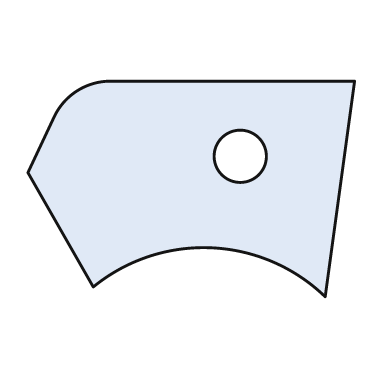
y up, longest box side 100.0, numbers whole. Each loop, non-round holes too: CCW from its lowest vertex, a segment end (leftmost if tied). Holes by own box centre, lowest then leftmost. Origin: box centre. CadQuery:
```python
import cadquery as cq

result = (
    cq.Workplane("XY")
    .moveTo(41.0, -33.0)
    .lineTo(50.0, 33.0)
    .lineTo(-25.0, 33.0)
    .threePointArc((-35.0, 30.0), (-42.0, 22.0))
    .lineTo(-50.0, 5.0)
    .lineTo(-30.0, -30.0)
    .threePointArc((6.0, -18.0), (41.0, -33.0))
    .close()
    .moveTo(15.0, 10.0)
    .circle(8.0)
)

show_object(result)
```